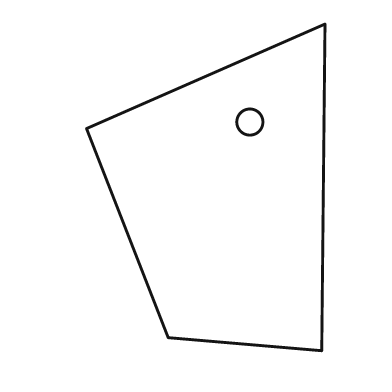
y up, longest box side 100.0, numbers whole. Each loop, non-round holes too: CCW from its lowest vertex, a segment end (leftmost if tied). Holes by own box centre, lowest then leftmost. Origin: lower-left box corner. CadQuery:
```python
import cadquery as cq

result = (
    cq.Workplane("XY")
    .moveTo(72.0, 0.0)
    .lineTo(73.0, 100.0)
    .lineTo(0.0, 68.0)
    .lineTo(25.0, 4.0)
    .close()
    .moveTo(50.0, 70.0)
    .circle(4.0)
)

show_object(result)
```